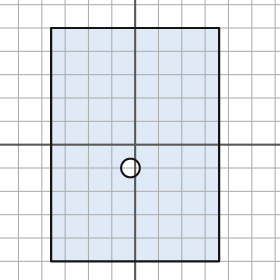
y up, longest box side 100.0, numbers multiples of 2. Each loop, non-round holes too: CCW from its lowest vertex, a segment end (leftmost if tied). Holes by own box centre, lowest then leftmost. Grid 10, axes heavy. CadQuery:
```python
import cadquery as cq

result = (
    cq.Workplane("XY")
    .moveTo(-36.0, -50.0)
    .lineTo(36.0, -50.0)
    .lineTo(36.0, 50.0)
    .lineTo(-36.0, 50.0)
    .close()
    .moveTo(-2.0, -10.0)
    .circle(4.0)
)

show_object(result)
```